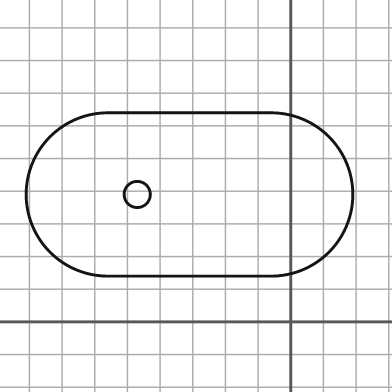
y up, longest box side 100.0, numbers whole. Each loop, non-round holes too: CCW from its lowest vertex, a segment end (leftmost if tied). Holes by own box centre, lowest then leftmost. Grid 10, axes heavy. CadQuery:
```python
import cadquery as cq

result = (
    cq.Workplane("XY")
    .moveTo(-56.0, 14.0)
    .lineTo(-6.0, 14.0)
    .threePointArc((19.0, 39.0), (-6.0, 64.0))
    .lineTo(-56.0, 64.0)
    .threePointArc((-81.0, 39.0), (-56.0, 14.0))
    .close()
    .moveTo(-47.0, 39.0)
    .circle(4.0)
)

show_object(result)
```